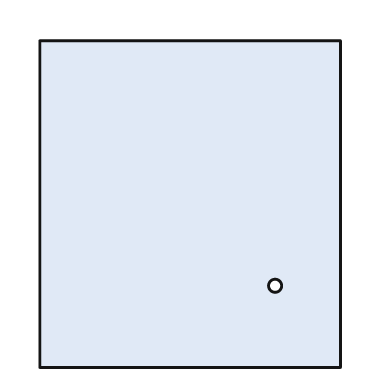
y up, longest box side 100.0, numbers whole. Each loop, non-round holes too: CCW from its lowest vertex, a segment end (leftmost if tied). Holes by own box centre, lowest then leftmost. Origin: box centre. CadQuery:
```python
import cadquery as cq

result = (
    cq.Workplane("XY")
    .moveTo(-46.0, -50.0)
    .lineTo(46.0, -50.0)
    .lineTo(46.0, 50.0)
    .lineTo(-46.0, 50.0)
    .close()
    .moveTo(26.0, -25.0)
    .circle(2.0)
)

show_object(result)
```